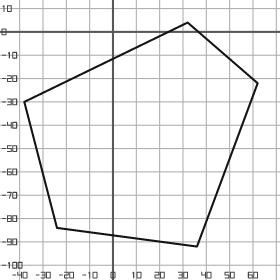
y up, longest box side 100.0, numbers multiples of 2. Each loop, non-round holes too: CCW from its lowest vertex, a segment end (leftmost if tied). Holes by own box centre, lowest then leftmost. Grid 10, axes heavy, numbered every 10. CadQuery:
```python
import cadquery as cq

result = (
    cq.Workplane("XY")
    .moveTo(36.0, -92.0)
    .lineTo(62.0, -22.0)
    .lineTo(32.0, 4.0)
    .lineTo(-38.0, -30.0)
    .lineTo(-24.0, -84.0)
    .close()
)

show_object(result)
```